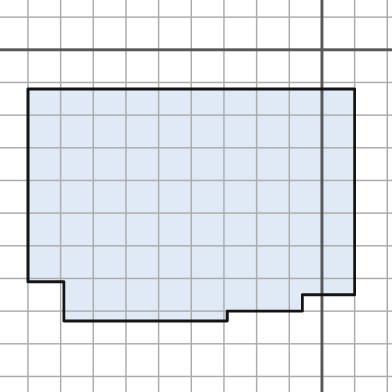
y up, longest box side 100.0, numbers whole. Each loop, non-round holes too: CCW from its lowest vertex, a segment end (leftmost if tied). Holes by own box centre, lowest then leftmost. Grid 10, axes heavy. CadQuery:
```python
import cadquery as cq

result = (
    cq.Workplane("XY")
    .moveTo(-79.0, -83.0)
    .lineTo(-29.0, -83.0)
    .lineTo(-29.0, -80.0)
    .lineTo(-6.0, -80.0)
    .lineTo(-6.0, -75.0)
    .lineTo(10.0, -75.0)
    .lineTo(10.0, -12.0)
    .lineTo(-90.0, -12.0)
    .lineTo(-90.0, -71.0)
    .lineTo(-79.0, -71.0)
    .close()
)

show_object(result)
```